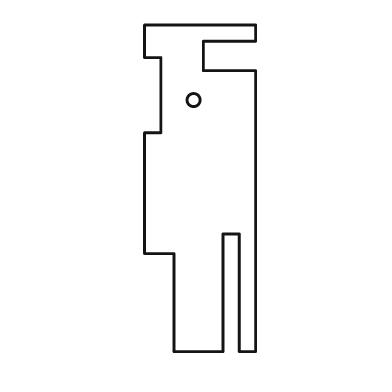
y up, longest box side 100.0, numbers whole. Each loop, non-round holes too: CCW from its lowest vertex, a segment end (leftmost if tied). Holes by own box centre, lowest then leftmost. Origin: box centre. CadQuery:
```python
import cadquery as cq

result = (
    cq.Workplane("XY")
    .moveTo(-8.0, -50.0)
    .lineTo(7.0, -50.0)
    .lineTo(7.0, -14.0)
    .lineTo(12.0, -14.0)
    .lineTo(12.0, -50.0)
    .lineTo(17.0, -50.0)
    .lineTo(17.0, 36.0)
    .lineTo(1.0, 36.0)
    .lineTo(1.0, 45.0)
    .lineTo(17.0, 45.0)
    .lineTo(17.0, 50.0)
    .lineTo(-17.0, 50.0)
    .lineTo(-17.0, 40.0)
    .lineTo(-12.0, 40.0)
    .lineTo(-12.0, 17.0)
    .lineTo(-17.0, 17.0)
    .lineTo(-17.0, -20.0)
    .lineTo(-8.0, -20.0)
    .close()
    .moveTo(-2.0, 27.0)
    .circle(2.0)
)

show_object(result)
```